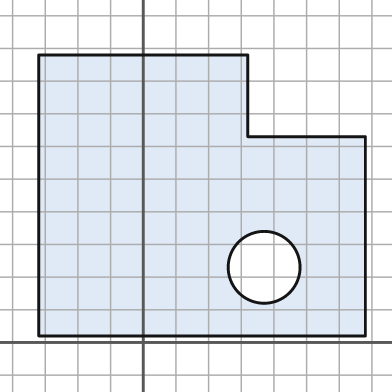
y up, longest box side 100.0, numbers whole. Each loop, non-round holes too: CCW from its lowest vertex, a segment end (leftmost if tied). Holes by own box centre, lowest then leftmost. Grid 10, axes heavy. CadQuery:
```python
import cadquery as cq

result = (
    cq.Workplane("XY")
    .moveTo(-32.0, 2.0)
    .lineTo(68.0, 2.0)
    .lineTo(68.0, 63.0)
    .lineTo(32.0, 63.0)
    .lineTo(32.0, 88.0)
    .lineTo(-32.0, 88.0)
    .close()
    .moveTo(37.0, 23.0)
    .circle(11.0)
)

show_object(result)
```